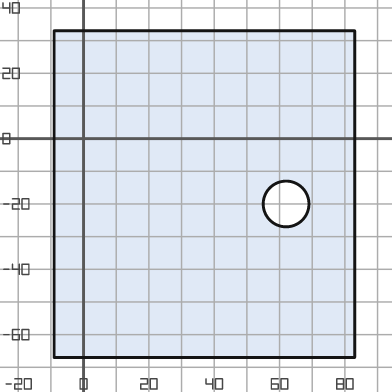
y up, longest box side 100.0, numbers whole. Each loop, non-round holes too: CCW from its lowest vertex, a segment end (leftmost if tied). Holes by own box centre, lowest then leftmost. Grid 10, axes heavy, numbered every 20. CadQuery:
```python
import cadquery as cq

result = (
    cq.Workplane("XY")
    .moveTo(-9.0, -67.0)
    .lineTo(83.0, -67.0)
    .lineTo(83.0, 33.0)
    .lineTo(-9.0, 33.0)
    .close()
    .moveTo(62.0, -20.0)
    .circle(7.0)
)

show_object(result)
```